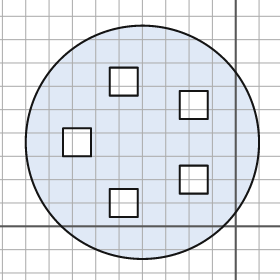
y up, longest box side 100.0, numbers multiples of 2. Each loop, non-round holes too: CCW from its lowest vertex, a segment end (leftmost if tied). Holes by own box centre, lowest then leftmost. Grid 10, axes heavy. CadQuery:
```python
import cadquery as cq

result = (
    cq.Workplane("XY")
    .moveTo(-40.0, 36.0)
    .circle(50.0)
    .moveTo(-54.0, 4.0)
    .lineTo(-42.0, 4.0)
    .lineTo(-42.0, 16.0)
    .lineTo(-54.0, 16.0)
    .close()
    .moveTo(-24.0, 14.0)
    .lineTo(-12.0, 14.0)
    .lineTo(-12.0, 26.0)
    .lineTo(-24.0, 26.0)
    .close()
    .moveTo(-74.0, 30.0)
    .lineTo(-62.0, 30.0)
    .lineTo(-62.0, 42.0)
    .lineTo(-74.0, 42.0)
    .close()
    .moveTo(-24.0, 46.0)
    .lineTo(-12.0, 46.0)
    .lineTo(-12.0, 58.0)
    .lineTo(-24.0, 58.0)
    .close()
    .moveTo(-54.0, 56.0)
    .lineTo(-42.0, 56.0)
    .lineTo(-42.0, 68.0)
    .lineTo(-54.0, 68.0)
    .close()
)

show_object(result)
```